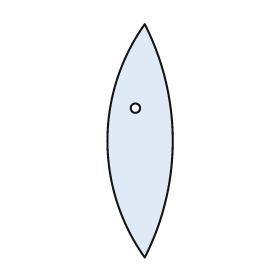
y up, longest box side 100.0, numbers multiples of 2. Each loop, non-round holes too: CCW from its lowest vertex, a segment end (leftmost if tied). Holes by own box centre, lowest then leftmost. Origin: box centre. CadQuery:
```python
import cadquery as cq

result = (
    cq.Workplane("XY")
    .moveTo(2.0, -50.0)
    .threePointArc((14.0, 0.0), (2.0, 50.0))
    .threePointArc((-14.0, 0.0), (2.0, -50.0))
    .close()
    .moveTo(-2.0, 14.0)
    .circle(2.0)
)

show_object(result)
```